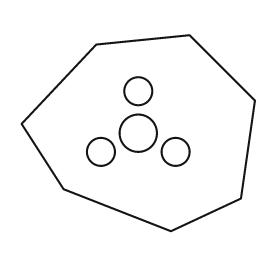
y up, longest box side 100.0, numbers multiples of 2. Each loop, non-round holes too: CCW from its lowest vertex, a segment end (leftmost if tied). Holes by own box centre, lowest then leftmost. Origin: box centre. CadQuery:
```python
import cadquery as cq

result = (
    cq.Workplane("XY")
    .moveTo(14.0, -42.0)
    .lineTo(44.0, -28.0)
    .lineTo(50.0, 14.0)
    .lineTo(22.0, 42.0)
    .lineTo(-18.0, 38.0)
    .lineTo(-50.0, 4.0)
    .lineTo(-32.0, -24.0)
    .close()
    .moveTo(-16.0, -8.0)
    .circle(6.0)
    .moveTo(16.0, -8.0)
    .circle(6.0)
    .moveTo(0.0, 0.0)
    .circle(8.0)
    .moveTo(0.0, 18.0)
    .circle(6.0)
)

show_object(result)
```